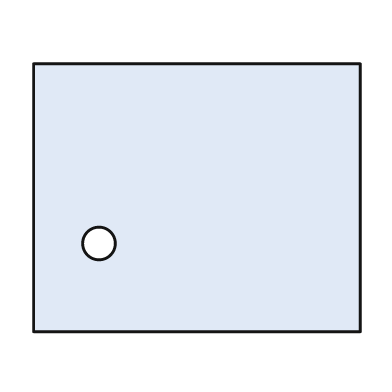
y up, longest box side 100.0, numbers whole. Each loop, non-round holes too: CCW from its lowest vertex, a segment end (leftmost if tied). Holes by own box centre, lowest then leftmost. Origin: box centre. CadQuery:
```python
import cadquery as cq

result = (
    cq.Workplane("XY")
    .moveTo(-50.0, -41.0)
    .lineTo(50.0, -41.0)
    .lineTo(50.0, 41.0)
    .lineTo(-50.0, 41.0)
    .close()
    .moveTo(-30.0, -14.0)
    .circle(5.0)
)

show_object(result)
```